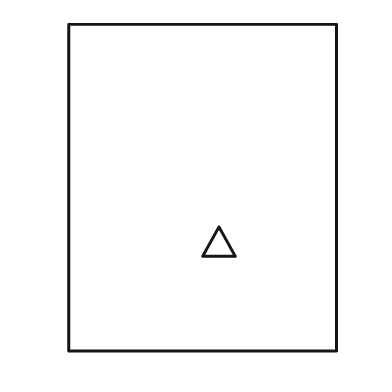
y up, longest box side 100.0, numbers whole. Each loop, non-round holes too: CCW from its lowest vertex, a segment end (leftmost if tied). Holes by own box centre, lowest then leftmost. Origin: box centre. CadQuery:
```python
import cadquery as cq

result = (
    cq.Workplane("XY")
    .moveTo(-41.0, -50.0)
    .lineTo(41.0, -50.0)
    .lineTo(41.0, 50.0)
    .lineTo(-41.0, 50.0)
    .close()
    .moveTo(0.0, -21.0)
    .lineTo(10.0, -21.0)
    .lineTo(5.0, -12.0)
    .close()
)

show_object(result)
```